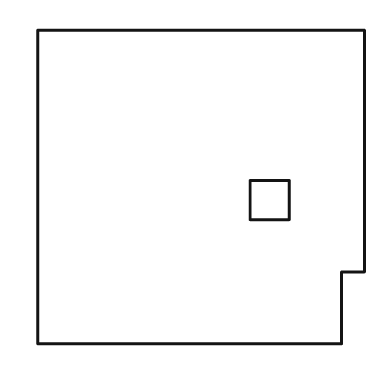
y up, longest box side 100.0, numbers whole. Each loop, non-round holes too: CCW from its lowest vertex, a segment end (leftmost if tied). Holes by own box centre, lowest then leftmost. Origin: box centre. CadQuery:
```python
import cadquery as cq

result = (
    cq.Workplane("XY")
    .moveTo(-50.0, -48.0)
    .lineTo(43.0, -48.0)
    .lineTo(43.0, -26.0)
    .lineTo(50.0, -26.0)
    .lineTo(50.0, 48.0)
    .lineTo(-50.0, 48.0)
    .close()
    .moveTo(15.0, -10.0)
    .lineTo(27.0, -10.0)
    .lineTo(27.0, 2.0)
    .lineTo(15.0, 2.0)
    .close()
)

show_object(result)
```